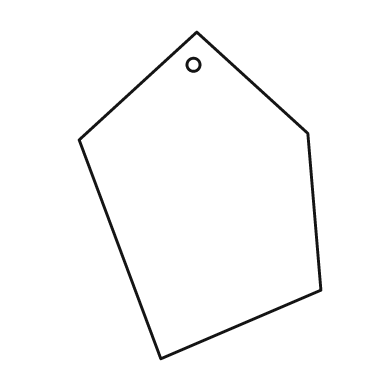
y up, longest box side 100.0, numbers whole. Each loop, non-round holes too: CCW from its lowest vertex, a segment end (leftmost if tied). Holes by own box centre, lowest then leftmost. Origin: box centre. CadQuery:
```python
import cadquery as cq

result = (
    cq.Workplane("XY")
    .moveTo(-12.0, -50.0)
    .lineTo(37.0, -29.0)
    .lineTo(33.0, 19.0)
    .lineTo(-1.0, 50.0)
    .lineTo(-37.0, 17.0)
    .close()
    .moveTo(-2.0, 40.0)
    .circle(2.0)
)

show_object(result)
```